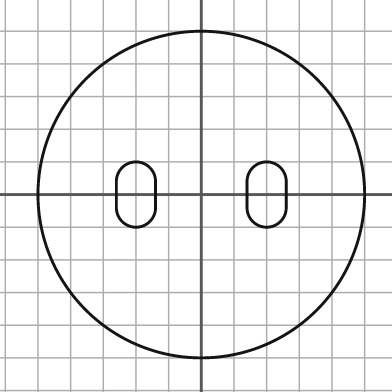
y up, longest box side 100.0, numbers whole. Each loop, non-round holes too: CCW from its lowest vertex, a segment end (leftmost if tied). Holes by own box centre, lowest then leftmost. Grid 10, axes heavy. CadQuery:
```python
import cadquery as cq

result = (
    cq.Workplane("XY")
    .moveTo(0.0, 0.0)
    .circle(50.0)
    .moveTo(-26.0, -4.0)
    .threePointArc((-20.0, -10.0), (-14.0, -4.0))
    .lineTo(-14.0, 4.0)
    .threePointArc((-20.0, 10.0), (-26.0, 4.0))
    .close()
    .moveTo(14.0, -4.0)
    .threePointArc((20.0, -10.0), (26.0, -4.0))
    .lineTo(26.0, 4.0)
    .threePointArc((20.0, 10.0), (14.0, 4.0))
    .close()
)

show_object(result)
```